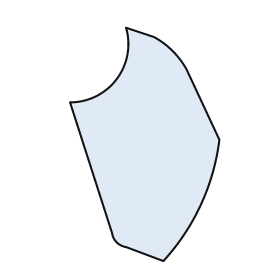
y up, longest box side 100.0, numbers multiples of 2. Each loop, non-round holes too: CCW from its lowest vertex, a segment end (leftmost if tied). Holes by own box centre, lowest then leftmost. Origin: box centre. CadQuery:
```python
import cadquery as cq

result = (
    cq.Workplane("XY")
    .moveTo(8.0, -50.0)
    .threePointArc((24.0, -26.0), (32.0, 2.0))
    .lineTo(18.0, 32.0)
    .threePointArc((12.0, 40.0), (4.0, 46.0))
    .lineTo(-8.0, 50.0)
    .threePointArc((-12.0, 28.0), (-32.0, 18.0))
    .lineTo(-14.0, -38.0)
    .threePointArc((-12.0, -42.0), (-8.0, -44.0))
    .close()
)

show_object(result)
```